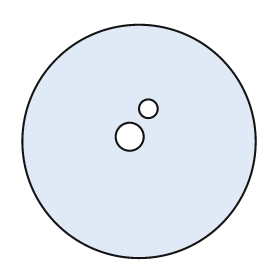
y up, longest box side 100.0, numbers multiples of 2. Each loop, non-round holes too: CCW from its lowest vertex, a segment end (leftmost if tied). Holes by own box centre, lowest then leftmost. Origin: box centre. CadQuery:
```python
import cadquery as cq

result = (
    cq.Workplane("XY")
    .moveTo(0.0, 0.0)
    .circle(50.0)
    .moveTo(-4.0, 2.0)
    .circle(6.0)
    .moveTo(4.0, 14.0)
    .circle(4.0)
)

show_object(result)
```